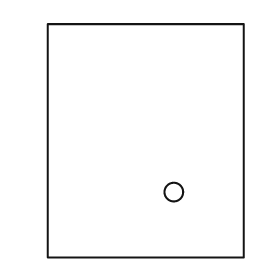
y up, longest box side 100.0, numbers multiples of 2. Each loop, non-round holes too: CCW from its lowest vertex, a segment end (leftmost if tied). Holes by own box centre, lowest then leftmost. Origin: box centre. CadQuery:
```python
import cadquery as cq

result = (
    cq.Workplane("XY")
    .moveTo(-42.0, -50.0)
    .lineTo(42.0, -50.0)
    .lineTo(42.0, 50.0)
    .lineTo(-42.0, 50.0)
    .close()
    .moveTo(12.0, -22.0)
    .circle(4.0)
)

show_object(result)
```